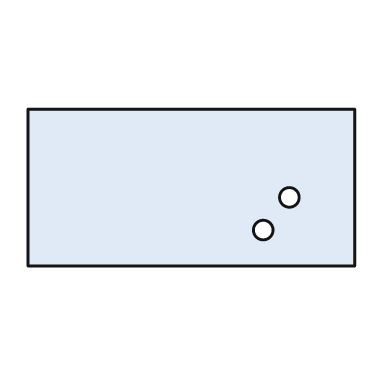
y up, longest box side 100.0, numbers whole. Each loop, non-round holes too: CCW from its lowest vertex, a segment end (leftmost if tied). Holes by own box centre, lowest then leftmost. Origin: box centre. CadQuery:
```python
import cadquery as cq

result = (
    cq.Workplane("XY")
    .moveTo(-50.0, -24.0)
    .lineTo(50.0, -24.0)
    .lineTo(50.0, 24.0)
    .lineTo(-50.0, 24.0)
    .close()
    .moveTo(22.0, -13.0)
    .circle(3.0)
    .moveTo(30.0, -3.0)
    .circle(3.0)
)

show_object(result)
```